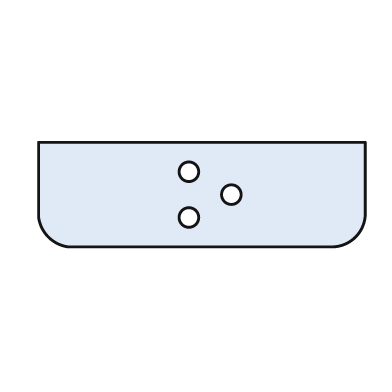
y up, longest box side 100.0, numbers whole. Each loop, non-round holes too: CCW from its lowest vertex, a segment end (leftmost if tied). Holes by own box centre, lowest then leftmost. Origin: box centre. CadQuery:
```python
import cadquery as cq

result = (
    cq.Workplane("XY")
    .moveTo(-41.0, -16.0)
    .lineTo(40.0, -16.0)
    .threePointArc((47.0, -13.0), (50.0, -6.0))
    .lineTo(50.0, 16.0)
    .lineTo(-50.0, 16.0)
    .lineTo(-50.0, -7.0)
    .threePointArc((-47.0, -13.0), (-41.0, -16.0))
    .close()
    .moveTo(-4.0, -7.0)
    .circle(3.0)
    .moveTo(9.0, 0.0)
    .circle(3.0)
    .moveTo(-4.0, 7.0)
    .circle(3.0)
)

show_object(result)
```